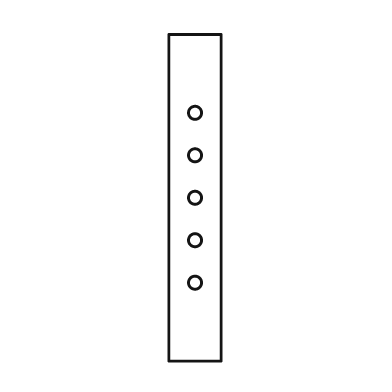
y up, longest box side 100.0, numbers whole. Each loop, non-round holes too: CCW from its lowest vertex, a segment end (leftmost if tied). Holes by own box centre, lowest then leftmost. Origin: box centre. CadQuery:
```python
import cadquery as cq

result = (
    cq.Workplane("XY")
    .moveTo(-8.0, -50.0)
    .lineTo(8.0, -50.0)
    .lineTo(8.0, 50.0)
    .lineTo(-8.0, 50.0)
    .close()
    .moveTo(0.0, -26.0)
    .circle(2.0)
    .moveTo(0.0, -13.0)
    .circle(2.0)
    .moveTo(0.0, 0.0)
    .circle(2.0)
    .moveTo(0.0, 13.0)
    .circle(2.0)
    .moveTo(0.0, 26.0)
    .circle(2.0)
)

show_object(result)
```